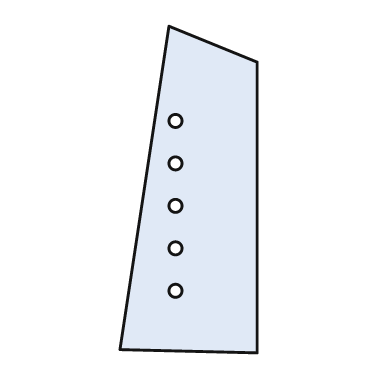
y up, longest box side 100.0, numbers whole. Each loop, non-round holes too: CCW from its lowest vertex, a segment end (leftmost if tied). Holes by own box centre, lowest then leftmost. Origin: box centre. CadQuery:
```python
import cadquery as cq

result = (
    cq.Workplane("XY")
    .moveTo(21.0, -50.0)
    .lineTo(21.0, 39.0)
    .lineTo(-6.0, 50.0)
    .lineTo(-21.0, -49.0)
    .close()
    .moveTo(-4.0, -31.0)
    .circle(2.0)
    .moveTo(-4.0, -18.0)
    .circle(2.0)
    .moveTo(-4.0, -5.0)
    .circle(2.0)
    .moveTo(-4.0, 8.0)
    .circle(2.0)
    .moveTo(-4.0, 21.0)
    .circle(2.0)
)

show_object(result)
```